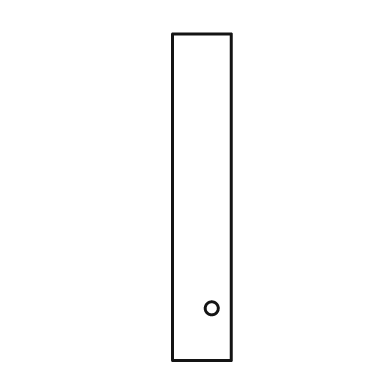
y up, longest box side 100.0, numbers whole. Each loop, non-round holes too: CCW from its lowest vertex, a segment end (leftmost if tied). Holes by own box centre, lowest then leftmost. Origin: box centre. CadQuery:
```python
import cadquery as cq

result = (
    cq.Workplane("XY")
    .moveTo(-9.0, -50.0)
    .lineTo(9.0, -50.0)
    .lineTo(9.0, 50.0)
    .lineTo(-9.0, 50.0)
    .close()
    .moveTo(3.0, -34.0)
    .circle(2.0)
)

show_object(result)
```